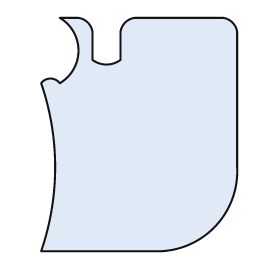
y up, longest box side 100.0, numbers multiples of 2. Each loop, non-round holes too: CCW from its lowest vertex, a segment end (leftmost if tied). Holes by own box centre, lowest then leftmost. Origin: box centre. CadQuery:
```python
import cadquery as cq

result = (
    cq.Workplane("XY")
    .moveTo(-42.0, -50.0)
    .lineTo(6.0, -50.0)
    .threePointArc((32.0, -40.0), (42.0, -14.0))
    .lineTo(42.0, 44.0)
    .threePointArc((40.0, 48.0), (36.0, 50.0))
    .lineTo(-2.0, 50.0)
    .threePointArc((-6.0, 48.0), (-8.0, 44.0))
    .lineTo(-8.0, 32.0)
    .threePointArc((-14.0, 30.0), (-20.0, 32.0))
    .lineTo(-20.0, 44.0)
    .threePointArc((-22.0, 48.0), (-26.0, 50.0))
    .lineTo(-34.0, 50.0)
    .threePointArc((-26.0, 36.0), (-34.0, 22.0))
    .threePointArc((-38.0, 24.0), (-42.0, 22.0))
    .threePointArc((-36.0, -14.0), (-42.0, -50.0))
    .close()
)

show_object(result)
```